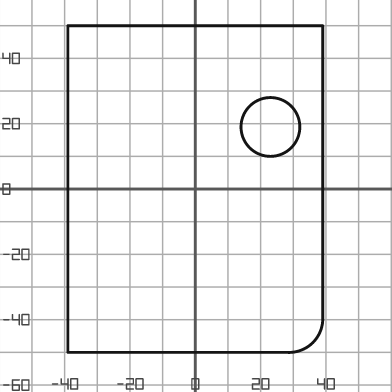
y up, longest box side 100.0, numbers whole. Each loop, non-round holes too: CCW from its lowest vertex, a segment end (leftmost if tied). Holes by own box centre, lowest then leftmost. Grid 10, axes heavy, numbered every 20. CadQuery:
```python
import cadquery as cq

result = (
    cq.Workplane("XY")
    .moveTo(-39.0, -50.0)
    .lineTo(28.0, -50.0)
    .threePointArc((36.0, -47.0), (39.0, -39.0))
    .lineTo(39.0, 50.0)
    .lineTo(-39.0, 50.0)
    .close()
    .moveTo(23.0, 19.0)
    .circle(9.0)
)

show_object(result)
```